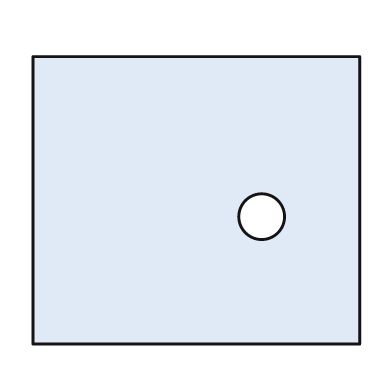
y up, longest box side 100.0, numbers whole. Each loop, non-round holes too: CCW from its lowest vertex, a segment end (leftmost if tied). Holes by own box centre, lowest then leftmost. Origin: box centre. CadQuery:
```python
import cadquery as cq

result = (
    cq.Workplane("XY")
    .moveTo(-50.0, -44.0)
    .lineTo(50.0, -44.0)
    .lineTo(50.0, 44.0)
    .lineTo(-50.0, 44.0)
    .close()
    .moveTo(20.0, -5.0)
    .circle(7.0)
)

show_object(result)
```